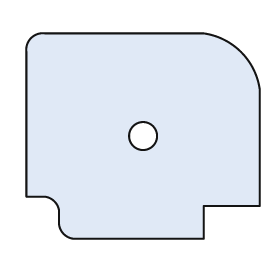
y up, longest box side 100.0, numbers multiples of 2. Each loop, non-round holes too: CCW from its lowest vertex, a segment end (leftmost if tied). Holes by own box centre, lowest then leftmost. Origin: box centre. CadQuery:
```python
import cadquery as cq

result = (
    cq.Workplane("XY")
    .moveTo(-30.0, -44.0)
    .lineTo(26.0, -44.0)
    .lineTo(26.0, -30.0)
    .lineTo(50.0, -30.0)
    .lineTo(50.0, 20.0)
    .threePointArc((42.0, 36.0), (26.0, 44.0))
    .lineTo(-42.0, 44.0)
    .threePointArc((-48.0, 42.0), (-50.0, 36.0))
    .lineTo(-50.0, -26.0)
    .lineTo(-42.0, -26.0)
    .threePointArc((-38.0, -28.0), (-36.0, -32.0))
    .lineTo(-36.0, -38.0)
    .threePointArc((-34.0, -42.0), (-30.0, -44.0))
    .close()
    .moveTo(0.0, 0.0)
    .circle(6.0)
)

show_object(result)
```